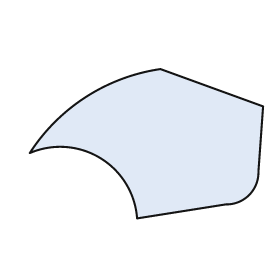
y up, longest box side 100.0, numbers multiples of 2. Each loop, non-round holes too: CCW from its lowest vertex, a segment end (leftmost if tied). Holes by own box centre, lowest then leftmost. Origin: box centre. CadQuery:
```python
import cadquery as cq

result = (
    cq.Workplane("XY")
    .moveTo(-4.0, -32.0)
    .lineTo(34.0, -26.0)
    .threePointArc((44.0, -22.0), (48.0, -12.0))
    .lineTo(50.0, 16.0)
    .lineTo(6.0, 32.0)
    .threePointArc((-26.0, 20.0), (-50.0, -4.0))
    .threePointArc((-20.0, -6.0), (-4.0, -32.0))
    .close()
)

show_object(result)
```